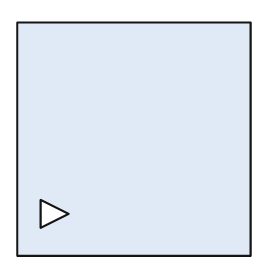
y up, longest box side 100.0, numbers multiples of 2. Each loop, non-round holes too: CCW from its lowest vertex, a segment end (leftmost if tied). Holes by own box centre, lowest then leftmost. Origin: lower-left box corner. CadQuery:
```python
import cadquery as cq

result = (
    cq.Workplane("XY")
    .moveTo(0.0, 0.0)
    .lineTo(100.0, 0.0)
    .lineTo(100.0, 100.0)
    .lineTo(0.0, 100.0)
    .close()
    .moveTo(10.0, 12.0)
    .lineTo(22.0, 18.0)
    .lineTo(10.0, 24.0)
    .close()
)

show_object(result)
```